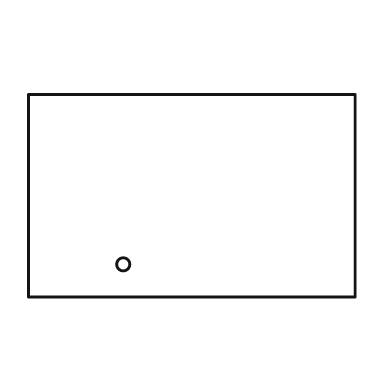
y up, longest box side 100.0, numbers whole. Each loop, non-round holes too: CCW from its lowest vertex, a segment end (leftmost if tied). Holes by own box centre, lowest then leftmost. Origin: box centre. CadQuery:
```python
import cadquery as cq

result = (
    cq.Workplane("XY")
    .moveTo(-50.0, -31.0)
    .lineTo(50.0, -31.0)
    .lineTo(50.0, 31.0)
    .lineTo(-50.0, 31.0)
    .close()
    .moveTo(-21.0, -21.0)
    .circle(2.0)
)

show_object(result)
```